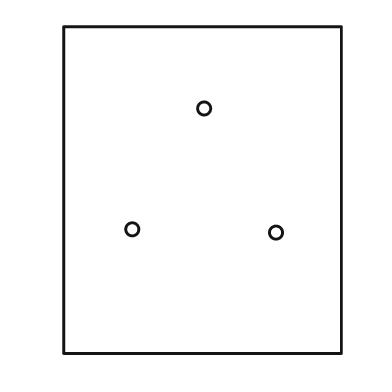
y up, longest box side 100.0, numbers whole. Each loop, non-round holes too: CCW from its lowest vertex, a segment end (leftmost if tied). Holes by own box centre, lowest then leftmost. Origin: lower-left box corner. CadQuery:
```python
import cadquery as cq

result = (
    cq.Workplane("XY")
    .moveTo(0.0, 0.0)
    .lineTo(85.0, 0.0)
    .lineTo(85.0, 100.0)
    .lineTo(0.0, 100.0)
    .close()
    .moveTo(65.0, 37.0)
    .circle(2.0)
    .moveTo(21.0, 38.0)
    .circle(2.0)
    .moveTo(43.0, 75.0)
    .circle(2.0)
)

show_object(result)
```